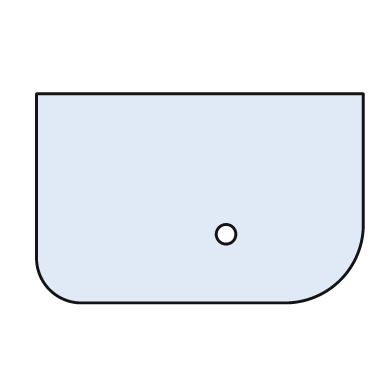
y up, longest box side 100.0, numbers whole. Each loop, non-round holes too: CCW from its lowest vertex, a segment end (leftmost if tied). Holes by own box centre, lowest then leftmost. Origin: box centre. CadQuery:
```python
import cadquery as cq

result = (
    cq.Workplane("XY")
    .moveTo(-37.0, -32.0)
    .lineTo(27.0, -32.0)
    .threePointArc((43.0, -25.0), (50.0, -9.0))
    .lineTo(50.0, 32.0)
    .lineTo(-50.0, 32.0)
    .lineTo(-50.0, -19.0)
    .threePointArc((-46.0, -28.0), (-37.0, -32.0))
    .close()
    .moveTo(8.0, -11.0)
    .circle(3.0)
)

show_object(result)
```